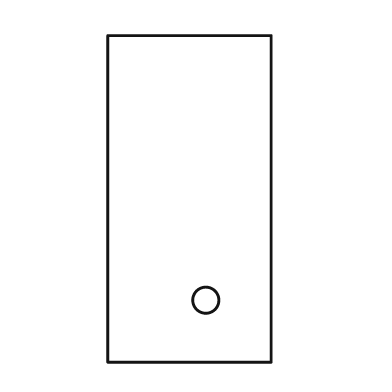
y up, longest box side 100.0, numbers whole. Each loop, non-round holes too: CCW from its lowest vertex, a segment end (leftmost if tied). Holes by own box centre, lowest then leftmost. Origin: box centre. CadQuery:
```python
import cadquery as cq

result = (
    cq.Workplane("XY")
    .moveTo(-25.0, -50.0)
    .lineTo(25.0, -50.0)
    .lineTo(25.0, 50.0)
    .lineTo(-25.0, 50.0)
    .close()
    .moveTo(5.0, -31.0)
    .circle(4.0)
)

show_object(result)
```